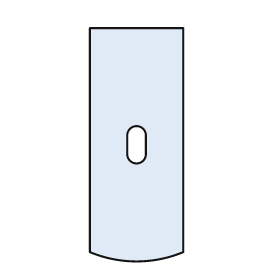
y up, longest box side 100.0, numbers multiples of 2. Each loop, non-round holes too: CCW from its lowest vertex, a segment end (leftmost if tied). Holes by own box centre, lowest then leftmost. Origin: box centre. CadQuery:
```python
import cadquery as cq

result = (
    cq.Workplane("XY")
    .moveTo(-20.0, -46.0)
    .threePointArc((0.0, -50.0), (20.0, -46.0))
    .lineTo(20.0, 50.0)
    .lineTo(-20.0, 50.0)
    .close()
    .moveTo(-4.0, -4.0)
    .threePointArc((0.0, -8.0), (4.0, -4.0))
    .lineTo(4.0, 4.0)
    .threePointArc((0.0, 8.0), (-4.0, 4.0))
    .close()
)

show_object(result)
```